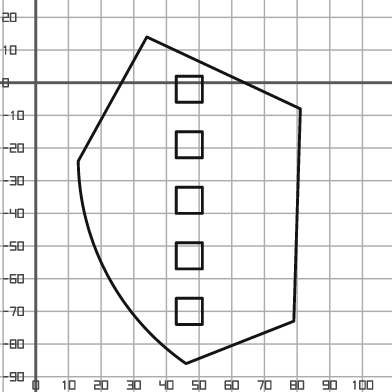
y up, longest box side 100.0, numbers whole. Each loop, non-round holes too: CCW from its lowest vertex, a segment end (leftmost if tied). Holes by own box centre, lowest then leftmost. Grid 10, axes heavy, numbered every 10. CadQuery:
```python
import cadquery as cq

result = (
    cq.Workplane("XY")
    .moveTo(46.0, -86.0)
    .lineTo(79.0, -73.0)
    .lineTo(81.0, -8.0)
    .lineTo(34.0, 14.0)
    .lineTo(13.0, -24.0)
    .threePointArc((22.0, -59.0), (46.0, -86.0))
    .close()
    .moveTo(43.0, -74.0)
    .lineTo(51.0, -74.0)
    .lineTo(51.0, -66.0)
    .lineTo(43.0, -66.0)
    .close()
    .moveTo(43.0, -57.0)
    .lineTo(51.0, -57.0)
    .lineTo(51.0, -49.0)
    .lineTo(43.0, -49.0)
    .close()
    .moveTo(43.0, -40.0)
    .lineTo(51.0, -40.0)
    .lineTo(51.0, -32.0)
    .lineTo(43.0, -32.0)
    .close()
    .moveTo(43.0, -23.0)
    .lineTo(51.0, -23.0)
    .lineTo(51.0, -15.0)
    .lineTo(43.0, -15.0)
    .close()
    .moveTo(43.0, -6.0)
    .lineTo(51.0, -6.0)
    .lineTo(51.0, 2.0)
    .lineTo(43.0, 2.0)
    .close()
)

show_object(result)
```